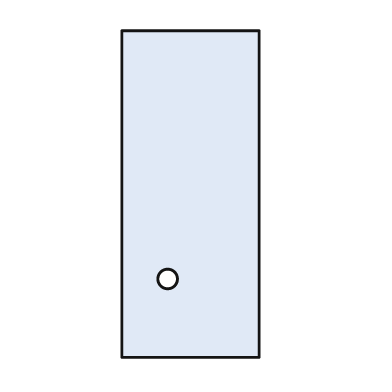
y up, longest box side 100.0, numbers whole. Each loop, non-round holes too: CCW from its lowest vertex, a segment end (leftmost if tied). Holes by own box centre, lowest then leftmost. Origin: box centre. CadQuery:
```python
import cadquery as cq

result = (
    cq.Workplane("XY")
    .moveTo(-21.0, -50.0)
    .lineTo(21.0, -50.0)
    .lineTo(21.0, 50.0)
    .lineTo(-21.0, 50.0)
    .close()
    .moveTo(-7.0, -26.0)
    .circle(3.0)
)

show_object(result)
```